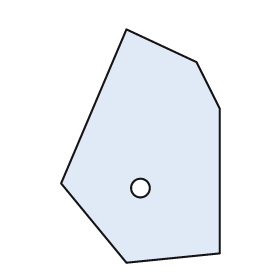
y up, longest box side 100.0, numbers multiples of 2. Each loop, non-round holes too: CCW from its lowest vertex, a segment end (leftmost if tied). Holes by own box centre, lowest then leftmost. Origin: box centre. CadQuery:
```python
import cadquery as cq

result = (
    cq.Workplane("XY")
    .moveTo(-6.0, -50.0)
    .lineTo(34.0, -46.0)
    .lineTo(34.0, 16.0)
    .lineTo(24.0, 36.0)
    .lineTo(-6.0, 50.0)
    .lineTo(-34.0, -16.0)
    .close()
    .moveTo(0.0, -18.0)
    .circle(4.0)
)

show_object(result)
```